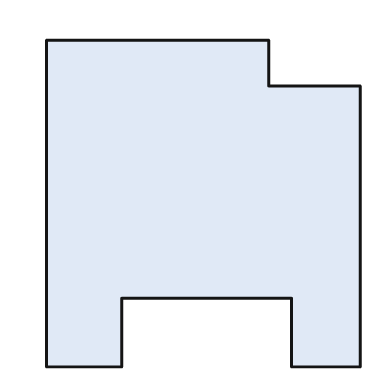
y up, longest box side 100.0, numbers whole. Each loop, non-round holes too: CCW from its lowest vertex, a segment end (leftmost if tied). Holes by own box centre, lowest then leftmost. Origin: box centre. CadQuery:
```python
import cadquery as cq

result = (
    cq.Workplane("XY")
    .moveTo(-48.0, -50.0)
    .lineTo(-25.0, -50.0)
    .lineTo(-25.0, -29.0)
    .lineTo(27.0, -29.0)
    .lineTo(27.0, -50.0)
    .lineTo(48.0, -50.0)
    .lineTo(48.0, 36.0)
    .lineTo(20.0, 36.0)
    .lineTo(20.0, 50.0)
    .lineTo(-48.0, 50.0)
    .close()
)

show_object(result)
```